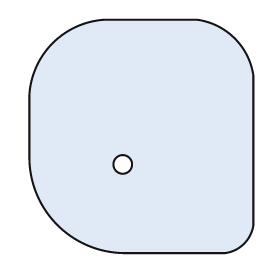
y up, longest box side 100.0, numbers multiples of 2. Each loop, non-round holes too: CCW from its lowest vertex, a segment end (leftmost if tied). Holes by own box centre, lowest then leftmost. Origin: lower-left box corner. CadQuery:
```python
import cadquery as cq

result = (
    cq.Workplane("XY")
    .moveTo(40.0, 0.0)
    .lineTo(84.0, 0.0)
    .threePointArc((92.0, 4.0), (96.0, 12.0))
    .lineTo(96.0, 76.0)
    .threePointArc((88.0, 92.0), (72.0, 100.0))
    .lineTo(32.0, 100.0)
    .threePointArc((10.0, 90.0), (0.0, 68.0))
    .lineTo(0.0, 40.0)
    .threePointArc((12.0, 12.0), (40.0, 0.0))
    .close()
    .moveTo(40.0, 38.0)
    .circle(4.0)
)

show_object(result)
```